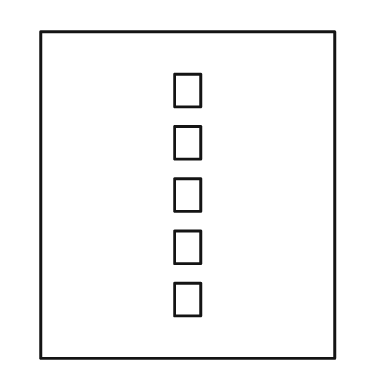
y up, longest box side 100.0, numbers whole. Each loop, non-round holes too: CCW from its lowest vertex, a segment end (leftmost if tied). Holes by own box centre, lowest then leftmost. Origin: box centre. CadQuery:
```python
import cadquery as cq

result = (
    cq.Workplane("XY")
    .moveTo(-45.0, -50.0)
    .lineTo(45.0, -50.0)
    .lineTo(45.0, 50.0)
    .lineTo(-45.0, 50.0)
    .close()
    .moveTo(-4.0, -37.0)
    .lineTo(4.0, -37.0)
    .lineTo(4.0, -27.0)
    .lineTo(-4.0, -27.0)
    .close()
    .moveTo(-4.0, -21.0)
    .lineTo(4.0, -21.0)
    .lineTo(4.0, -11.0)
    .lineTo(-4.0, -11.0)
    .close()
    .moveTo(-4.0, -5.0)
    .lineTo(4.0, -5.0)
    .lineTo(4.0, 5.0)
    .lineTo(-4.0, 5.0)
    .close()
    .moveTo(-4.0, 11.0)
    .lineTo(4.0, 11.0)
    .lineTo(4.0, 21.0)
    .lineTo(-4.0, 21.0)
    .close()
    .moveTo(-4.0, 27.0)
    .lineTo(4.0, 27.0)
    .lineTo(4.0, 37.0)
    .lineTo(-4.0, 37.0)
    .close()
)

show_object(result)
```